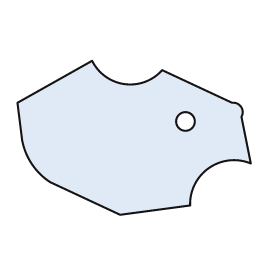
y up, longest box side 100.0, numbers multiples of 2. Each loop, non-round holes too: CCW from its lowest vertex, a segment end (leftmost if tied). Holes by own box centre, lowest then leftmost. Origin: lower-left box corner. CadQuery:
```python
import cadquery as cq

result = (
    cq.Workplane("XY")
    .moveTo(44.0, 0.0)
    .lineTo(74.0, 4.0)
    .threePointArc((82.0, 20.0), (100.0, 22.0))
    .lineTo(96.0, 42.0)
    .threePointArc((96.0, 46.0), (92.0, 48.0))
    .lineTo(62.0, 62.0)
    .threePointArc((46.0, 56.0), (32.0, 66.0))
    .lineTo(0.0, 48.0)
    .lineTo(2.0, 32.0)
    .threePointArc((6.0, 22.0), (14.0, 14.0))
    .close()
    .moveTo(72.0, 40.0)
    .circle(4.0)
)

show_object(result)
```